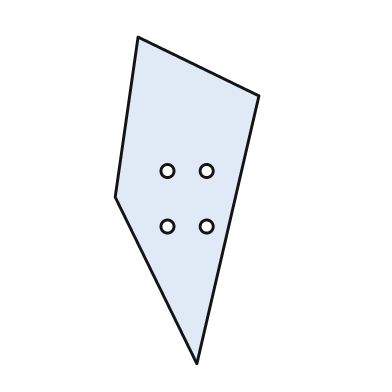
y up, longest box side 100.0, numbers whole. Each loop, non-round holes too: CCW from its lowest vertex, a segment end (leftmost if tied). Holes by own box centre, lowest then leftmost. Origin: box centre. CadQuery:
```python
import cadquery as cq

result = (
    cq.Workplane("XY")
    .moveTo(3.0, -50.0)
    .lineTo(22.0, 32.0)
    .lineTo(-15.0, 50.0)
    .lineTo(-22.0, 1.0)
    .close()
    .moveTo(-6.0, -8.0)
    .circle(2.0)
    .moveTo(6.0, -8.0)
    .circle(2.0)
    .moveTo(-6.0, 9.0)
    .circle(2.0)
    .moveTo(6.0, 9.0)
    .circle(2.0)
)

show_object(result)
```